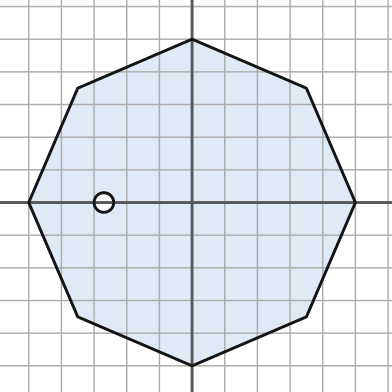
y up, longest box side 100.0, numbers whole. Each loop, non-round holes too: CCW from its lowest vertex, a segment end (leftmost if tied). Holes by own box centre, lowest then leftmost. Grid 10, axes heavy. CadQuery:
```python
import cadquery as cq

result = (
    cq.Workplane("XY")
    .moveTo(0.0, -50.0)
    .lineTo(35.0, -35.0)
    .lineTo(50.0, 0.0)
    .lineTo(35.0, 35.0)
    .lineTo(0.0, 50.0)
    .lineTo(-35.0, 35.0)
    .lineTo(-50.0, 0.0)
    .lineTo(-35.0, -35.0)
    .close()
    .moveTo(-27.0, 0.0)
    .circle(3.0)
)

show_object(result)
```